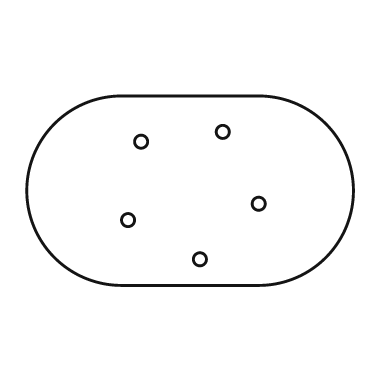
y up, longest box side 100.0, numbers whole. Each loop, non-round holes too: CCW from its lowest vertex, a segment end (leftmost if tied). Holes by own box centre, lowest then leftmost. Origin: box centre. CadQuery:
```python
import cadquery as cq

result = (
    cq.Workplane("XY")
    .moveTo(-21.0, -29.0)
    .lineTo(21.0, -29.0)
    .threePointArc((50.0, 0.0), (21.0, 29.0))
    .lineTo(-21.0, 29.0)
    .threePointArc((-50.0, 0.0), (-21.0, -29.0))
    .close()
    .moveTo(3.0, -21.0)
    .circle(2.0)
    .moveTo(-19.0, -9.0)
    .circle(2.0)
    .moveTo(21.0, -4.0)
    .circle(2.0)
    .moveTo(-15.0, 15.0)
    .circle(2.0)
    .moveTo(10.0, 18.0)
    .circle(2.0)
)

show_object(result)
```